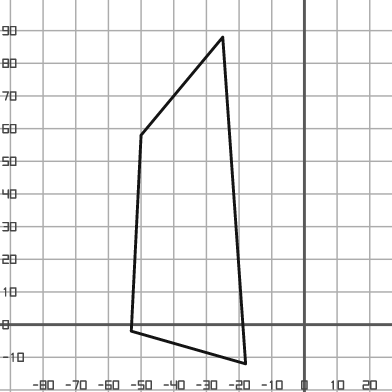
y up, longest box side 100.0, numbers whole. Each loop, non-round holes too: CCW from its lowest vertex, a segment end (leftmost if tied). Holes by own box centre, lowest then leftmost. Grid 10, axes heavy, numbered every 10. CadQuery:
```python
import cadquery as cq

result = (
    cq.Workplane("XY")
    .moveTo(-18.0, -12.0)
    .lineTo(-25.0, 88.0)
    .lineTo(-50.0, 58.0)
    .lineTo(-53.0, -2.0)
    .close()
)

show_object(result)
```